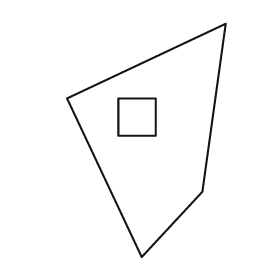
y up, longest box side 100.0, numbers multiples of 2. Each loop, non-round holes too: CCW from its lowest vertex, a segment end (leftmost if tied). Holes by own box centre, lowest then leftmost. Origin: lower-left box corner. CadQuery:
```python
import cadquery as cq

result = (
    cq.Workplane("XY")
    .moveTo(32.0, 0.0)
    .lineTo(58.0, 28.0)
    .lineTo(68.0, 100.0)
    .lineTo(0.0, 68.0)
    .close()
    .moveTo(22.0, 52.0)
    .lineTo(38.0, 52.0)
    .lineTo(38.0, 68.0)
    .lineTo(22.0, 68.0)
    .close()
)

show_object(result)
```